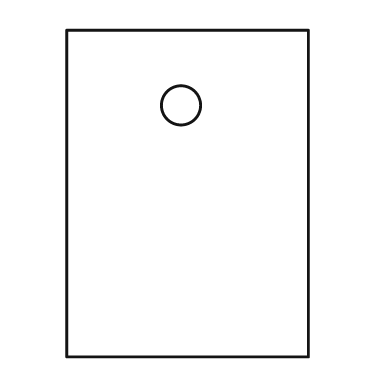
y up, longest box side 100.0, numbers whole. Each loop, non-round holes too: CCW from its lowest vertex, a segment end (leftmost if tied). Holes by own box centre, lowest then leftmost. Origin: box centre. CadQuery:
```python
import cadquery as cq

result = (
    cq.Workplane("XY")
    .moveTo(-37.0, -50.0)
    .lineTo(37.0, -50.0)
    .lineTo(37.0, 50.0)
    .lineTo(-37.0, 50.0)
    .close()
    .moveTo(-2.0, 27.0)
    .circle(6.0)
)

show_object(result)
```